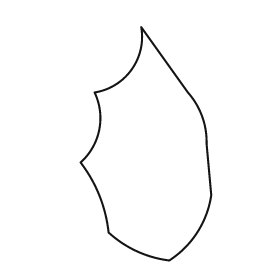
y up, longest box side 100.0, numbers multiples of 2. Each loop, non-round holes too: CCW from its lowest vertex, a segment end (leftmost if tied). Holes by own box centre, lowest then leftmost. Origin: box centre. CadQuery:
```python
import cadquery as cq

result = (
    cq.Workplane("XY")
    .moveTo(10.0, -50.0)
    .threePointArc((22.0, -38.0), (28.0, -22.0))
    .lineTo(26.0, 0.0)
    .threePointArc((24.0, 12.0), (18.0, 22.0))
    .lineTo(-2.0, 50.0)
    .threePointArc((-6.0, 32.0), (-22.0, 22.0))
    .threePointArc((-20.0, 6.0), (-28.0, -8.0))
    .threePointArc((-20.0, -22.0), (-16.0, -38.0))
    .threePointArc((-4.0, -46.0), (10.0, -50.0))
    .close()
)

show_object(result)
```